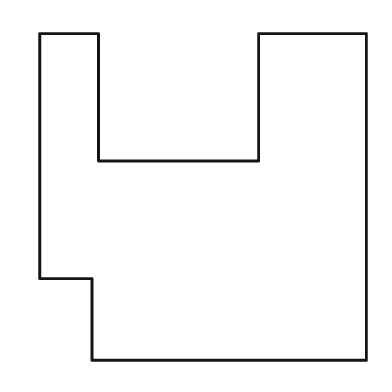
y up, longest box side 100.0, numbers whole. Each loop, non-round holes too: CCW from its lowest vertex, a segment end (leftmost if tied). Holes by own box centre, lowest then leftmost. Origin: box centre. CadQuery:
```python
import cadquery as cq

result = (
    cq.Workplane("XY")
    .moveTo(-34.0, -50.0)
    .lineTo(50.0, -50.0)
    .lineTo(50.0, 50.0)
    .lineTo(17.0, 50.0)
    .lineTo(17.0, 11.0)
    .lineTo(-32.0, 11.0)
    .lineTo(-32.0, 50.0)
    .lineTo(-50.0, 50.0)
    .lineTo(-50.0, -25.0)
    .lineTo(-34.0, -25.0)
    .close()
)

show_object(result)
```